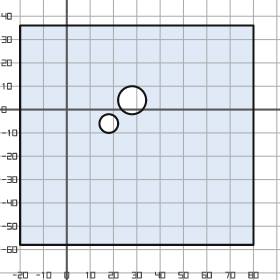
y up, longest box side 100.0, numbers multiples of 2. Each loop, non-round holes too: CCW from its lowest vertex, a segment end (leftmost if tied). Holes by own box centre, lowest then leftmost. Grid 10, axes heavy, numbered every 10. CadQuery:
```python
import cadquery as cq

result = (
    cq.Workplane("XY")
    .moveTo(-20.0, -58.0)
    .lineTo(80.0, -58.0)
    .lineTo(80.0, 36.0)
    .lineTo(-20.0, 36.0)
    .close()
    .moveTo(18.0, -6.0)
    .circle(4.0)
    .moveTo(28.0, 4.0)
    .circle(6.0)
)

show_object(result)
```